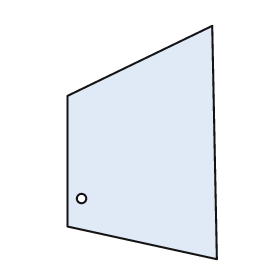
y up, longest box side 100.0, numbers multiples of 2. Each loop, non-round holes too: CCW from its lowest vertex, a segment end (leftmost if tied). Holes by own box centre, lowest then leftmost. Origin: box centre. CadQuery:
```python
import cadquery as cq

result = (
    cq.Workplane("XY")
    .moveTo(32.0, -50.0)
    .lineTo(30.0, 50.0)
    .lineTo(-32.0, 20.0)
    .lineTo(-32.0, -36.0)
    .close()
    .moveTo(-26.0, -24.0)
    .circle(2.0)
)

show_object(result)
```